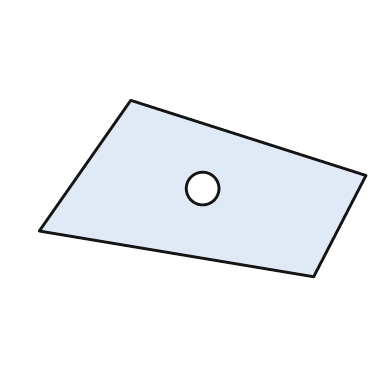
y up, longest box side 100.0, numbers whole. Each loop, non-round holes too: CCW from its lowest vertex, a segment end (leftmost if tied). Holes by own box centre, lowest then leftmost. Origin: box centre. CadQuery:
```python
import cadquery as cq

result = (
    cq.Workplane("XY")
    .moveTo(34.0, -27.0)
    .lineTo(50.0, 4.0)
    .lineTo(-22.0, 27.0)
    .lineTo(-50.0, -13.0)
    .close()
    .moveTo(0.0, 0.0)
    .circle(5.0)
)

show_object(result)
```